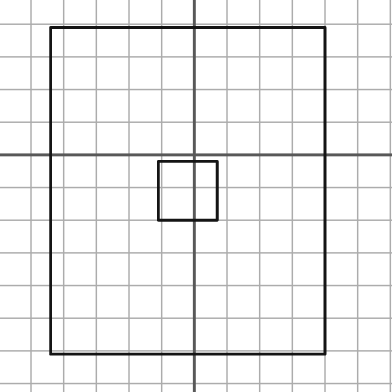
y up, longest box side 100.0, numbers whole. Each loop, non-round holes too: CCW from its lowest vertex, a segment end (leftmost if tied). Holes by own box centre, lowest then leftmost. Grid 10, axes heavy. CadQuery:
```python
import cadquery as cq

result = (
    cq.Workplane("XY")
    .moveTo(-44.0, -61.0)
    .lineTo(40.0, -61.0)
    .lineTo(40.0, 39.0)
    .lineTo(-44.0, 39.0)
    .close()
    .moveTo(-11.0, -20.0)
    .lineTo(7.0, -20.0)
    .lineTo(7.0, -2.0)
    .lineTo(-11.0, -2.0)
    .close()
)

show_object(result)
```